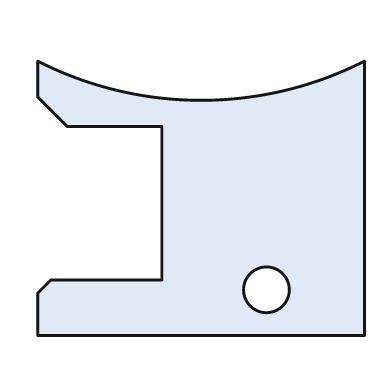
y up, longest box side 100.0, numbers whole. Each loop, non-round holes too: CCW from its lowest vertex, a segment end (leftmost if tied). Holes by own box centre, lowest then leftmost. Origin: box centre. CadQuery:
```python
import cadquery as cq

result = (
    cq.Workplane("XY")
    .moveTo(-50.0, -42.0)
    .lineTo(50.0, -42.0)
    .lineTo(50.0, 42.0)
    .threePointArc((0.0, 30.0), (-50.0, 42.0))
    .lineTo(-50.0, 31.0)
    .lineTo(-41.0, 22.0)
    .lineTo(-12.0, 22.0)
    .lineTo(-12.0, -25.0)
    .lineTo(-46.0, -25.0)
    .lineTo(-50.0, -29.0)
    .close()
    .moveTo(20.0, -28.0)
    .circle(7.0)
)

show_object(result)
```